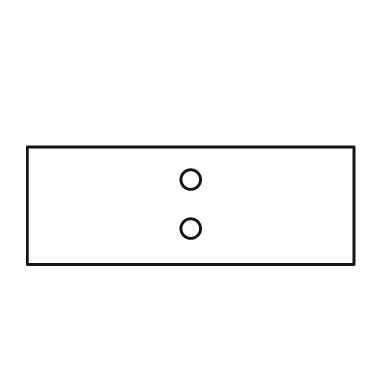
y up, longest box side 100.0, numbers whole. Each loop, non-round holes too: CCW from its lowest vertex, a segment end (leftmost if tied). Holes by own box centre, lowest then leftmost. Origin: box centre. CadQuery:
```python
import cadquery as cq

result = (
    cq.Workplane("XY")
    .moveTo(-50.0, -18.0)
    .lineTo(50.0, -18.0)
    .lineTo(50.0, 18.0)
    .lineTo(-50.0, 18.0)
    .close()
    .moveTo(0.0, -7.0)
    .circle(3.0)
    .moveTo(0.0, 8.0)
    .circle(3.0)
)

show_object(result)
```